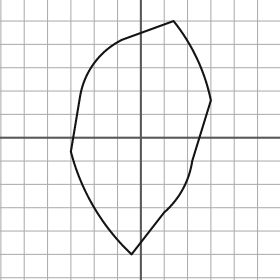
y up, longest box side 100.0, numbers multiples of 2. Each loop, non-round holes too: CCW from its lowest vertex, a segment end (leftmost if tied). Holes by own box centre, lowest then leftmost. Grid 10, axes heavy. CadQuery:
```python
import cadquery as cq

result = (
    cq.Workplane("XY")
    .moveTo(-4.0, -50.0)
    .lineTo(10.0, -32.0)
    .threePointArc((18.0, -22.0), (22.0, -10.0))
    .lineTo(30.0, 16.0)
    .threePointArc((24.0, 34.0), (14.0, 50.0))
    .lineTo(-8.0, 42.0)
    .threePointArc((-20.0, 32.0), (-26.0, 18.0))
    .lineTo(-30.0, -6.0)
    .threePointArc((-20.0, -30.0), (-4.0, -50.0))
    .close()
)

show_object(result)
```